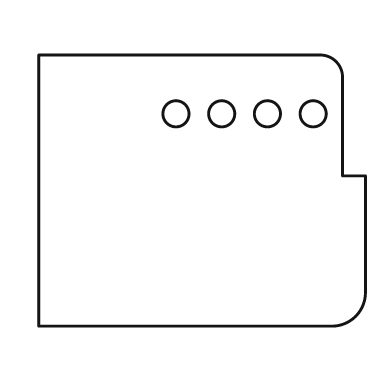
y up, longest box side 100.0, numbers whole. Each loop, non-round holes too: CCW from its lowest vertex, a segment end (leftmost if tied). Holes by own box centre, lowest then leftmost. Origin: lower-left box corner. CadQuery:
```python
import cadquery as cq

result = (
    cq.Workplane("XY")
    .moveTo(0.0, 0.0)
    .lineTo(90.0, 0.0)
    .threePointArc((97.0, 3.0), (100.0, 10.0))
    .lineTo(100.0, 46.0)
    .lineTo(93.0, 46.0)
    .lineTo(93.0, 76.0)
    .threePointArc((91.0, 81.0), (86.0, 83.0))
    .lineTo(0.0, 83.0)
    .close()
    .moveTo(42.0, 65.0)
    .circle(4.0)
    .moveTo(56.0, 65.0)
    .circle(4.0)
    .moveTo(70.0, 65.0)
    .circle(4.0)
    .moveTo(84.0, 65.0)
    .circle(4.0)
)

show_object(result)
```